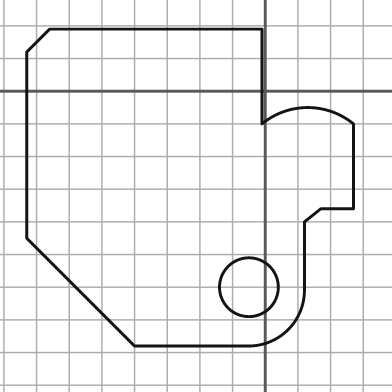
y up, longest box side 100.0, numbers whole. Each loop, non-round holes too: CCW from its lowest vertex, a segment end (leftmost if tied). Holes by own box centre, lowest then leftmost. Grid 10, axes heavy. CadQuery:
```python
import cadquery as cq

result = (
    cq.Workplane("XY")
    .moveTo(-40.0, -78.0)
    .lineTo(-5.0, -78.0)
    .threePointArc((7.0, -73.0), (12.0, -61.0))
    .lineTo(12.0, -40.0)
    .lineTo(17.0, -36.0)
    .lineTo(27.0, -36.0)
    .lineTo(27.0, -10.0)
    .threePointArc((13.0, -5.0), (-1.0, -10.0))
    .lineTo(-1.0, 19.0)
    .lineTo(-66.0, 19.0)
    .lineTo(-73.0, 12.0)
    .lineTo(-73.0, -45.0)
    .close()
    .moveTo(-5.0, -60.0)
    .circle(9.0)
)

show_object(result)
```